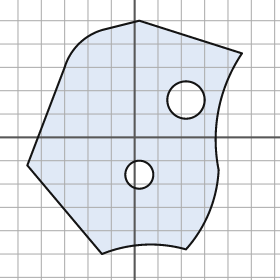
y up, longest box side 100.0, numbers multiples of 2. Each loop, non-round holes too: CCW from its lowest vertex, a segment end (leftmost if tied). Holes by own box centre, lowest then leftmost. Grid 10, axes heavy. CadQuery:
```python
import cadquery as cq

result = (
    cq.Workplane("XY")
    .moveTo(-14.0, -50.0)
    .threePointArc((4.0, -46.0), (22.0, -48.0))
    .threePointArc((32.0, -32.0), (36.0, -14.0))
    .threePointArc((36.0, 12.0), (46.0, 36.0))
    .lineTo(2.0, 50.0)
    .lineTo(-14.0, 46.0)
    .threePointArc((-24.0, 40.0), (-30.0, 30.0))
    .lineTo(-46.0, -12.0)
    .close()
    .moveTo(2.0, -16.0)
    .circle(6.0)
    .moveTo(22.0, 16.0)
    .circle(8.0)
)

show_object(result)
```